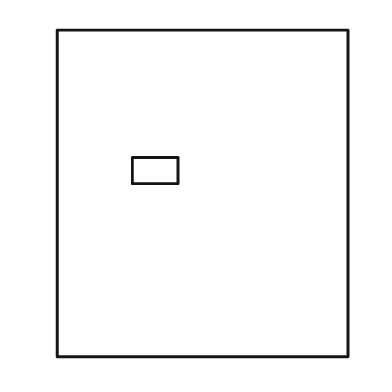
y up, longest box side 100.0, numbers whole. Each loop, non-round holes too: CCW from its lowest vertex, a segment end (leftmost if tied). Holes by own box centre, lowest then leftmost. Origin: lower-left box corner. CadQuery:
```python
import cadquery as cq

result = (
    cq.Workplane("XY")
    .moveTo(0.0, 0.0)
    .lineTo(89.0, 0.0)
    .lineTo(89.0, 100.0)
    .lineTo(0.0, 100.0)
    .close()
    .moveTo(23.0, 53.0)
    .lineTo(37.0, 53.0)
    .lineTo(37.0, 61.0)
    .lineTo(23.0, 61.0)
    .close()
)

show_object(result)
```